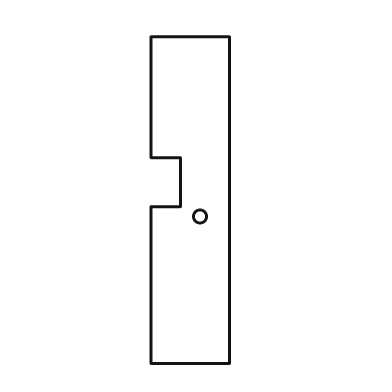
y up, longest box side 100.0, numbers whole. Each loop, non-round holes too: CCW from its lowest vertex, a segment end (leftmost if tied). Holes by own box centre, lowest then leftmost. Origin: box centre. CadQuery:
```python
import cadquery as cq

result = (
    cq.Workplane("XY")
    .moveTo(-12.0, -50.0)
    .lineTo(12.0, -50.0)
    .lineTo(12.0, 50.0)
    .lineTo(-12.0, 50.0)
    .lineTo(-12.0, 13.0)
    .lineTo(-3.0, 13.0)
    .lineTo(-3.0, -2.0)
    .lineTo(-12.0, -2.0)
    .close()
    .moveTo(3.0, -5.0)
    .circle(2.0)
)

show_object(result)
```